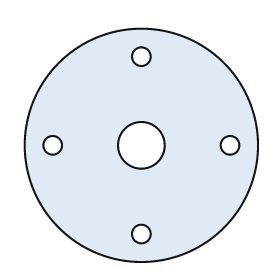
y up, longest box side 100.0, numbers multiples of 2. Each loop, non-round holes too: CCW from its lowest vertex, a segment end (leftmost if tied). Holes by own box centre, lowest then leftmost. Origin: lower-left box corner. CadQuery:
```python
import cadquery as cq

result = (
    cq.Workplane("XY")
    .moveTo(50.0, 50.0)
    .circle(50.0)
    .moveTo(50.0, 12.0)
    .circle(4.0)
    .moveTo(12.0, 50.0)
    .circle(4.0)
    .moveTo(50.0, 50.0)
    .circle(10.0)
    .moveTo(88.0, 50.0)
    .circle(4.0)
    .moveTo(50.0, 88.0)
    .circle(4.0)
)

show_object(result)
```